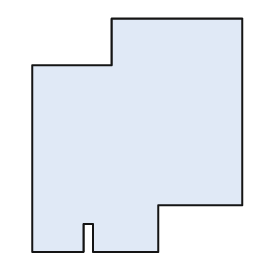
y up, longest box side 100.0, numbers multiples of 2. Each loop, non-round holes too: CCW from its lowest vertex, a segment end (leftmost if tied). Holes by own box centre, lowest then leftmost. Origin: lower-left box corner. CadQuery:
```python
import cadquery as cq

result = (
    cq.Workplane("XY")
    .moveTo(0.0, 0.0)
    .lineTo(22.0, 0.0)
    .lineTo(22.0, 12.0)
    .lineTo(26.0, 12.0)
    .lineTo(26.0, 0.0)
    .lineTo(54.0, 0.0)
    .lineTo(54.0, 20.0)
    .lineTo(90.0, 20.0)
    .lineTo(90.0, 100.0)
    .lineTo(34.0, 100.0)
    .lineTo(34.0, 80.0)
    .lineTo(0.0, 80.0)
    .close()
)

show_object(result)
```